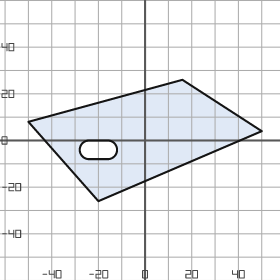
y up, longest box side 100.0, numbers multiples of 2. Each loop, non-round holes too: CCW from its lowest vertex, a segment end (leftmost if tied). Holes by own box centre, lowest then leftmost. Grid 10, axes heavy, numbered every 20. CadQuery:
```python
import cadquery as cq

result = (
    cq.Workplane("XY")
    .moveTo(-20.0, -26.0)
    .lineTo(50.0, 4.0)
    .lineTo(16.0, 26.0)
    .lineTo(-50.0, 8.0)
    .close()
    .moveTo(-24.0, -8.0)
    .lineTo(-16.0, -8.0)
    .threePointArc((-12.0, -4.0), (-16.0, 0.0))
    .lineTo(-24.0, 0.0)
    .threePointArc((-28.0, -4.0), (-24.0, -8.0))
    .close()
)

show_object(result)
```